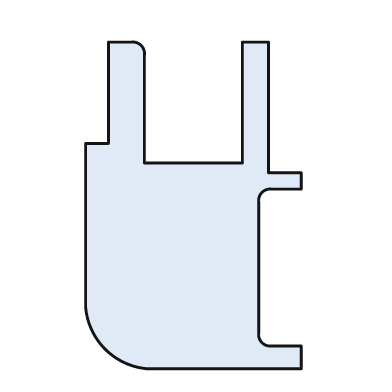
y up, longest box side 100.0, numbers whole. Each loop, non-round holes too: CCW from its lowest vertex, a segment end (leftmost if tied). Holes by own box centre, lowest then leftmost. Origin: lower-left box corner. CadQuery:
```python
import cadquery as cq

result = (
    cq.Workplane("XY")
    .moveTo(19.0, 0.0)
    .lineTo(66.0, 0.0)
    .lineTo(66.0, 7.0)
    .lineTo(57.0, 7.0)
    .threePointArc((54.0, 8.0), (53.0, 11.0))
    .lineTo(53.0, 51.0)
    .threePointArc((54.0, 54.0), (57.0, 55.0))
    .lineTo(66.0, 55.0)
    .lineTo(66.0, 60.0)
    .lineTo(56.0, 60.0)
    .lineTo(56.0, 100.0)
    .lineTo(48.0, 100.0)
    .lineTo(48.0, 63.0)
    .lineTo(18.0, 63.0)
    .lineTo(18.0, 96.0)
    .threePointArc((17.0, 99.0), (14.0, 100.0))
    .lineTo(7.0, 100.0)
    .lineTo(7.0, 69.0)
    .lineTo(0.0, 69.0)
    .lineTo(0.0, 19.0)
    .threePointArc((6.0, 6.0), (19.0, 0.0))
    .close()
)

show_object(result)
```